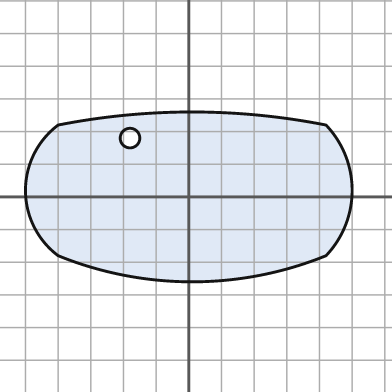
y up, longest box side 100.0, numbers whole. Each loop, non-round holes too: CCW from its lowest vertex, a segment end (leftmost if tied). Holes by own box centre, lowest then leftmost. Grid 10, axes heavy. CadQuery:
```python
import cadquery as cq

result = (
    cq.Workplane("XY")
    .moveTo(-40.0, -18.0)
    .threePointArc((1.0, -26.0), (42.0, -18.0))
    .threePointArc((50.0, 2.0), (42.0, 22.0))
    .threePointArc((1.0, 26.0), (-40.0, 22.0))
    .threePointArc((-50.0, 2.0), (-40.0, -18.0))
    .close()
    .moveTo(-18.0, 18.0)
    .circle(3.0)
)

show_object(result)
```